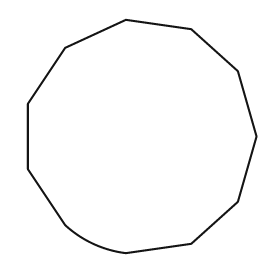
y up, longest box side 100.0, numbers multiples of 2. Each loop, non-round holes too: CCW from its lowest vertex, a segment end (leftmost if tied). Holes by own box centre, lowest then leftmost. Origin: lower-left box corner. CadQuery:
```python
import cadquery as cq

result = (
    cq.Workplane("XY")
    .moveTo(42.0, 0.0)
    .lineTo(70.0, 4.0)
    .lineTo(90.0, 22.0)
    .lineTo(98.0, 50.0)
    .lineTo(90.0, 78.0)
    .lineTo(70.0, 96.0)
    .lineTo(42.0, 100.0)
    .lineTo(16.0, 88.0)
    .lineTo(0.0, 64.0)
    .lineTo(0.0, 36.0)
    .lineTo(16.0, 12.0)
    .threePointArc((28.0, 4.0), (42.0, 0.0))
    .close()
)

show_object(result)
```